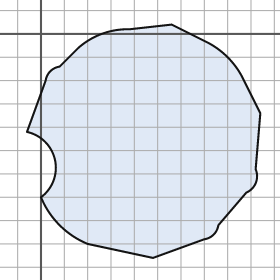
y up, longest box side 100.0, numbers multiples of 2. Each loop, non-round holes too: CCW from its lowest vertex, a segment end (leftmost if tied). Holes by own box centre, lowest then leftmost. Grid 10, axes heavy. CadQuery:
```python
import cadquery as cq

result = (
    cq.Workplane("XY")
    .moveTo(48.0, -96.0)
    .lineTo(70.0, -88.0)
    .threePointArc((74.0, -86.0), (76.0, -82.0))
    .lineTo(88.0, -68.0)
    .threePointArc((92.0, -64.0), (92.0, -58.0))
    .lineTo(94.0, -34.0)
    .lineTo(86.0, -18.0)
    .threePointArc((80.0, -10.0), (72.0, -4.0))
    .lineTo(56.0, 4.0)
    .lineTo(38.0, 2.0)
    .threePointArc((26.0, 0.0), (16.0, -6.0))
    .lineTo(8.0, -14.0)
    .threePointArc((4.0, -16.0), (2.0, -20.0))
    .lineTo(-6.0, -42.0)
    .threePointArc((6.0, -54.0), (0.0, -70.0))
    .threePointArc((8.0, -82.0), (20.0, -90.0))
    .close()
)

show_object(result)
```